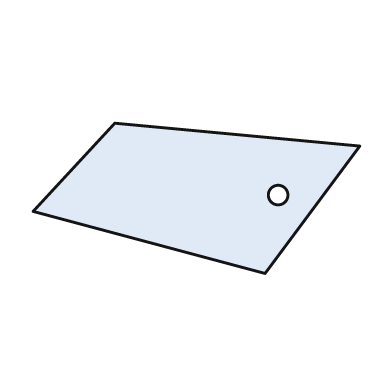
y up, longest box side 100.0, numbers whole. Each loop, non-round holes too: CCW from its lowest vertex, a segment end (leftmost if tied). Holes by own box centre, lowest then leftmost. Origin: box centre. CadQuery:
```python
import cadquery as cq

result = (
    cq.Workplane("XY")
    .moveTo(21.0, -23.0)
    .lineTo(50.0, 16.0)
    .lineTo(-25.0, 23.0)
    .lineTo(-50.0, -4.0)
    .close()
    .moveTo(25.0, 1.0)
    .circle(3.0)
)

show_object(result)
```